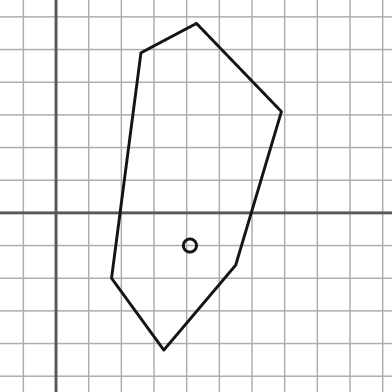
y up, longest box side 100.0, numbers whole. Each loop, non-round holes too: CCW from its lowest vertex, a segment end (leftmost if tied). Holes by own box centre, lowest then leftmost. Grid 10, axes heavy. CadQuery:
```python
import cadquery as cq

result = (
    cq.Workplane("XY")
    .moveTo(33.0, -42.0)
    .lineTo(55.0, -16.0)
    .lineTo(69.0, 31.0)
    .lineTo(43.0, 58.0)
    .lineTo(26.0, 49.0)
    .lineTo(17.0, -20.0)
    .close()
    .moveTo(41.0, -10.0)
    .circle(2.0)
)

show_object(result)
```